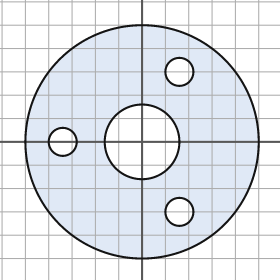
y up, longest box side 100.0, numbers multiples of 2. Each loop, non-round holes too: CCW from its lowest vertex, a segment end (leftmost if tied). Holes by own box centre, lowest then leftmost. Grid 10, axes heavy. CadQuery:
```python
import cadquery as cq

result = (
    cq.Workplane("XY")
    .moveTo(0.0, 0.0)
    .circle(50.0)
    .moveTo(16.0, -30.0)
    .circle(6.0)
    .moveTo(-34.0, 0.0)
    .circle(6.0)
    .moveTo(0.0, 0.0)
    .circle(16.0)
    .moveTo(16.0, 30.0)
    .circle(6.0)
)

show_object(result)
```